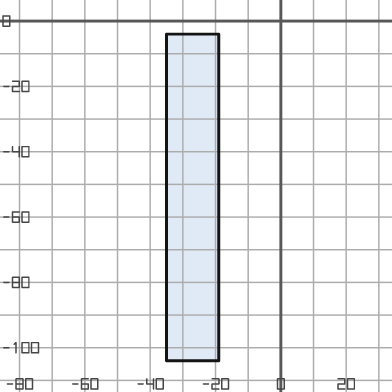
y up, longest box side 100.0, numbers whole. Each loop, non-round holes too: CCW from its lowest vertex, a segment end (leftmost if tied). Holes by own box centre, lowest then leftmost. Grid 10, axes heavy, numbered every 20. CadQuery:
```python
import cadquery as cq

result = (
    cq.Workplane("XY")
    .moveTo(-35.0, -104.0)
    .lineTo(-19.0, -104.0)
    .lineTo(-19.0, -4.0)
    .lineTo(-35.0, -4.0)
    .close()
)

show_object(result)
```